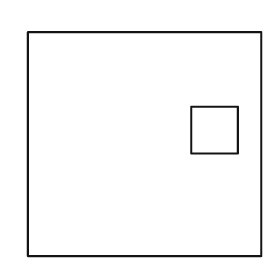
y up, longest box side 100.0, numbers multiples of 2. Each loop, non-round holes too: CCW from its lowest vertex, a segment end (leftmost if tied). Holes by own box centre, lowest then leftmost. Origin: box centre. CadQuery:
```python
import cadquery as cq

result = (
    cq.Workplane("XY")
    .moveTo(-50.0, -48.0)
    .lineTo(50.0, -48.0)
    .lineTo(50.0, 48.0)
    .lineTo(-50.0, 48.0)
    .close()
    .moveTo(20.0, -4.0)
    .lineTo(40.0, -4.0)
    .lineTo(40.0, 16.0)
    .lineTo(20.0, 16.0)
    .close()
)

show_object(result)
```